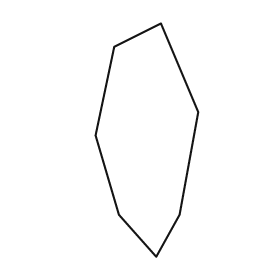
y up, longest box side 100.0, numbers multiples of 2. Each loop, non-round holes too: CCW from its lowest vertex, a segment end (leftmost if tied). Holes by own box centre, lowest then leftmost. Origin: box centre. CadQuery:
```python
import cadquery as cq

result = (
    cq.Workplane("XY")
    .moveTo(4.0, -50.0)
    .lineTo(14.0, -32.0)
    .lineTo(22.0, 12.0)
    .lineTo(6.0, 50.0)
    .lineTo(-14.0, 40.0)
    .lineTo(-22.0, 2.0)
    .lineTo(-12.0, -32.0)
    .close()
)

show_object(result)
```